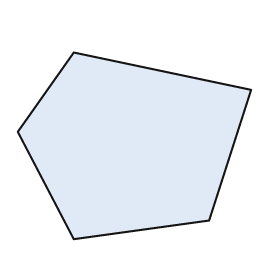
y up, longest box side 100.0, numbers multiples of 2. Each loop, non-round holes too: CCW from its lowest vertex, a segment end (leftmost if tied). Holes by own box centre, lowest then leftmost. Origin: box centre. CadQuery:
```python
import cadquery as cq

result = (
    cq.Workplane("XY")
    .moveTo(-26.0, -40.0)
    .lineTo(32.0, -32.0)
    .lineTo(50.0, 24.0)
    .lineTo(-26.0, 40.0)
    .lineTo(-50.0, 6.0)
    .close()
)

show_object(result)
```